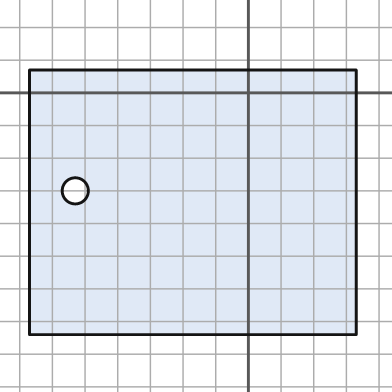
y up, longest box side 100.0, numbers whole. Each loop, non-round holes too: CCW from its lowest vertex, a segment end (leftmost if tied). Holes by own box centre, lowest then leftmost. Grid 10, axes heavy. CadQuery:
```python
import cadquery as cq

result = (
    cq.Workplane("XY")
    .moveTo(-67.0, -74.0)
    .lineTo(33.0, -74.0)
    .lineTo(33.0, 7.0)
    .lineTo(-67.0, 7.0)
    .close()
    .moveTo(-53.0, -30.0)
    .circle(4.0)
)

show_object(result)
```